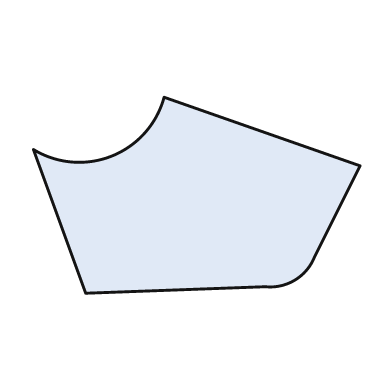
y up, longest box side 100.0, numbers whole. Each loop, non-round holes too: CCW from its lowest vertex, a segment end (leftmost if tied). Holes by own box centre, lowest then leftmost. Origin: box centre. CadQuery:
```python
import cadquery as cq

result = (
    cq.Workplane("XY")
    .moveTo(-34.0, -30.0)
    .lineTo(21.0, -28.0)
    .threePointArc((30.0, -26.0), (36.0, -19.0))
    .lineTo(50.0, 9.0)
    .lineTo(-10.0, 30.0)
    .threePointArc((-26.0, 12.0), (-50.0, 14.0))
    .close()
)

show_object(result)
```